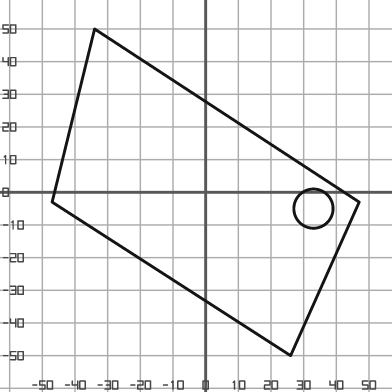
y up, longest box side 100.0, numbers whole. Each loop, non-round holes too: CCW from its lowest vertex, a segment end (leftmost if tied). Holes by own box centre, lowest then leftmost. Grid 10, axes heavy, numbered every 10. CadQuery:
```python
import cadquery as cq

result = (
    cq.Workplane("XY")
    .moveTo(26.0, -50.0)
    .lineTo(47.0, -3.0)
    .lineTo(-34.0, 50.0)
    .lineTo(-47.0, -3.0)
    .close()
    .moveTo(33.0, -5.0)
    .circle(6.0)
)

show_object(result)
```